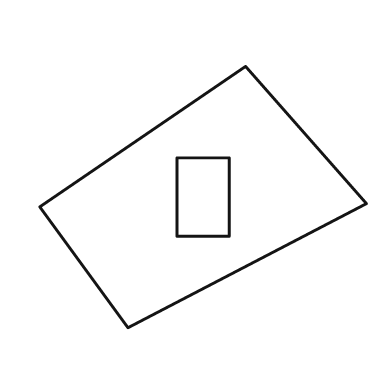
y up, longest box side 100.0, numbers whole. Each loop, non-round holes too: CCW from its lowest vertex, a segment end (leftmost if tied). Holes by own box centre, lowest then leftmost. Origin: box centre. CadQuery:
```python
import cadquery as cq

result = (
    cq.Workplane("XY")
    .moveTo(-23.0, -40.0)
    .lineTo(50.0, -2.0)
    .lineTo(13.0, 40.0)
    .lineTo(-50.0, -3.0)
    .close()
    .moveTo(-8.0, -12.0)
    .lineTo(8.0, -12.0)
    .lineTo(8.0, 12.0)
    .lineTo(-8.0, 12.0)
    .close()
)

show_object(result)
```